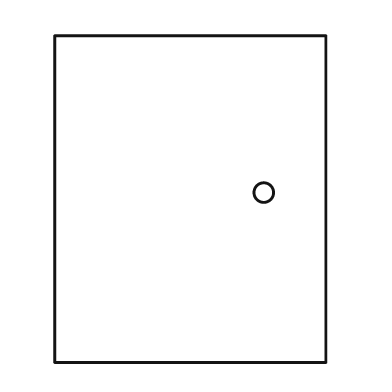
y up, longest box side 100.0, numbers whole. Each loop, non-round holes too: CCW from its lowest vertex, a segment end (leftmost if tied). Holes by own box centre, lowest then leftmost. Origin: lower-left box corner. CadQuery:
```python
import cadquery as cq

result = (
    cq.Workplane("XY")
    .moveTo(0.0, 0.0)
    .lineTo(83.0, 0.0)
    .lineTo(83.0, 100.0)
    .lineTo(0.0, 100.0)
    .close()
    .moveTo(64.0, 52.0)
    .circle(3.0)
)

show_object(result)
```